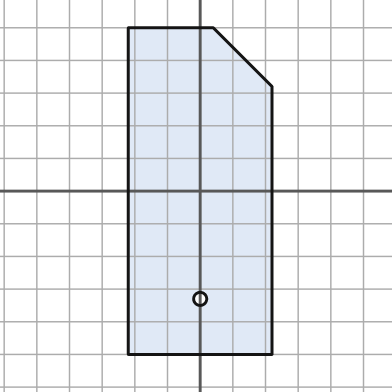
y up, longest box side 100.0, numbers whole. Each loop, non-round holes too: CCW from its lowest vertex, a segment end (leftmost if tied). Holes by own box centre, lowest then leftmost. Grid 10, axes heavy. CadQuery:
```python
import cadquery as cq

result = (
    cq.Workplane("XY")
    .moveTo(-22.0, -50.0)
    .lineTo(22.0, -50.0)
    .lineTo(22.0, 32.0)
    .lineTo(4.0, 50.0)
    .lineTo(-22.0, 50.0)
    .close()
    .moveTo(0.0, -33.0)
    .circle(2.0)
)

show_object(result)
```